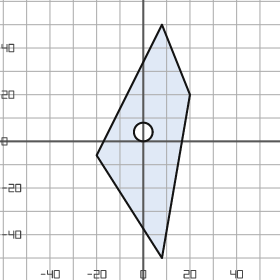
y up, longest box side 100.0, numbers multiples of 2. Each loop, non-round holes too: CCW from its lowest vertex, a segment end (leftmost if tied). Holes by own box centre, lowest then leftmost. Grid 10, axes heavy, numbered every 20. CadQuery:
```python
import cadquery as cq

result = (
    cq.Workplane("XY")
    .moveTo(8.0, -50.0)
    .lineTo(20.0, 20.0)
    .lineTo(8.0, 50.0)
    .lineTo(-20.0, -6.0)
    .close()
    .moveTo(0.0, 4.0)
    .circle(4.0)
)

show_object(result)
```